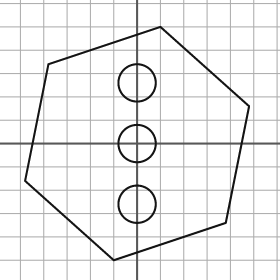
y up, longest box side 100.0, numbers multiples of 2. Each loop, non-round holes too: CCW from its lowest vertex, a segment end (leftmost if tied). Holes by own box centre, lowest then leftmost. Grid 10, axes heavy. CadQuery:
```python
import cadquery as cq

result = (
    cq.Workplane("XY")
    .moveTo(-10.0, -50.0)
    .lineTo(38.0, -34.0)
    .lineTo(48.0, 16.0)
    .lineTo(10.0, 50.0)
    .lineTo(-38.0, 34.0)
    .lineTo(-48.0, -16.0)
    .close()
    .moveTo(0.0, -26.0)
    .circle(8.0)
    .moveTo(0.0, 0.0)
    .circle(8.0)
    .moveTo(0.0, 26.0)
    .circle(8.0)
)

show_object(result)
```